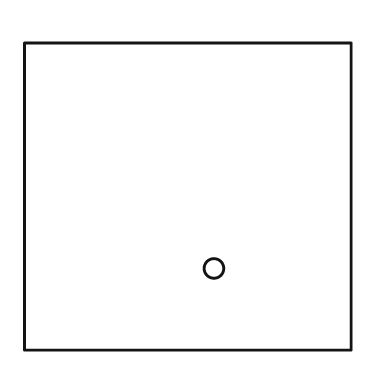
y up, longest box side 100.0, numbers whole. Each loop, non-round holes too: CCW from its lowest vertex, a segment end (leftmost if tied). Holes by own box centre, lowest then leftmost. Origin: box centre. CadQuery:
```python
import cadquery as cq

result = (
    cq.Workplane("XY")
    .moveTo(-50.0, -47.0)
    .lineTo(50.0, -47.0)
    .lineTo(50.0, 47.0)
    .lineTo(-50.0, 47.0)
    .close()
    .moveTo(8.0, -22.0)
    .circle(3.0)
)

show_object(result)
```